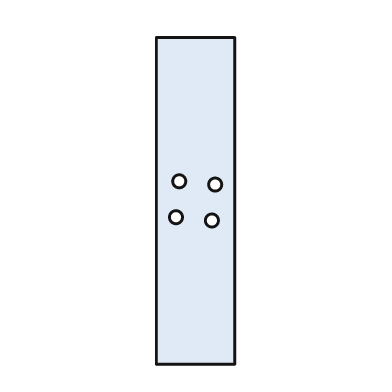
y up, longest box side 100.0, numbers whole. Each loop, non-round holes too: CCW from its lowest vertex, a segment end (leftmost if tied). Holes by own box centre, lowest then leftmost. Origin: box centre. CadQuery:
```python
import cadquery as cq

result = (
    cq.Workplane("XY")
    .moveTo(-12.0, -50.0)
    .lineTo(12.0, -50.0)
    .lineTo(12.0, 50.0)
    .lineTo(-12.0, 50.0)
    .close()
    .moveTo(5.0, -6.0)
    .circle(2.0)
    .moveTo(-6.0, -5.0)
    .circle(2.0)
    .moveTo(6.0, 5.0)
    .circle(2.0)
    .moveTo(-5.0, 6.0)
    .circle(2.0)
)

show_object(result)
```